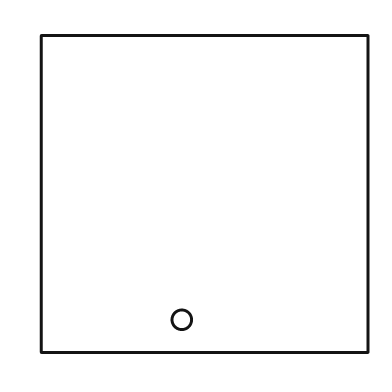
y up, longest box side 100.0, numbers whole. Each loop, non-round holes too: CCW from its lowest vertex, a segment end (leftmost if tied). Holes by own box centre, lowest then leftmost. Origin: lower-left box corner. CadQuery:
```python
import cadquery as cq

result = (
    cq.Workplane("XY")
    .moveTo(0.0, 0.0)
    .lineTo(100.0, 0.0)
    .lineTo(100.0, 97.0)
    .lineTo(0.0, 97.0)
    .close()
    .moveTo(43.0, 10.0)
    .circle(3.0)
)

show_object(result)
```